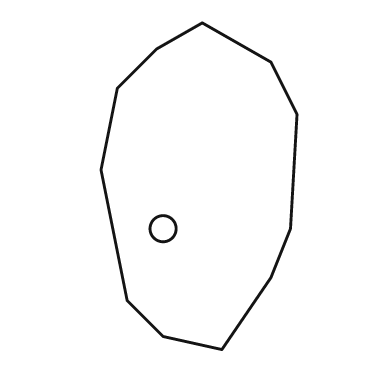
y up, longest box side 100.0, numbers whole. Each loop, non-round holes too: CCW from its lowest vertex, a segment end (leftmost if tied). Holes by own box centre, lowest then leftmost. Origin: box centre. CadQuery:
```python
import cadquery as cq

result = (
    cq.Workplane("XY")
    .moveTo(7.0, -50.0)
    .lineTo(22.0, -28.0)
    .lineTo(28.0, -13.0)
    .lineTo(30.0, 22.0)
    .lineTo(22.0, 38.0)
    .lineTo(1.0, 50.0)
    .lineTo(-13.0, 42.0)
    .lineTo(-25.0, 30.0)
    .lineTo(-30.0, 5.0)
    .lineTo(-22.0, -35.0)
    .lineTo(-11.0, -46.0)
    .close()
    .moveTo(-11.0, -13.0)
    .circle(4.0)
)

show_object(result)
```